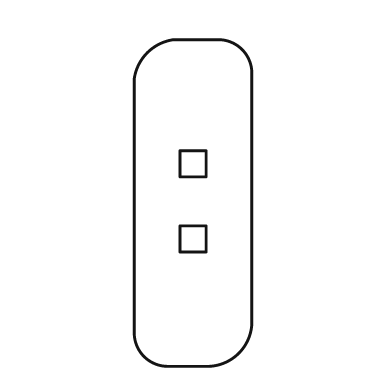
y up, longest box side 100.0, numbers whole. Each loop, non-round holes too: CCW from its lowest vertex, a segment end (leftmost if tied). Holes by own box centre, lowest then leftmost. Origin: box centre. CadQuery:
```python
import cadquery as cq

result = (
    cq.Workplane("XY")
    .moveTo(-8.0, -50.0)
    .lineTo(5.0, -50.0)
    .threePointArc((14.0, -46.0), (18.0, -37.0))
    .lineTo(18.0, 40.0)
    .threePointArc((15.0, 47.0), (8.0, 50.0))
    .lineTo(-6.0, 50.0)
    .threePointArc((-14.0, 46.0), (-18.0, 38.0))
    .lineTo(-18.0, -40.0)
    .threePointArc((-15.0, -47.0), (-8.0, -50.0))
    .close()
    .moveTo(-4.0, -15.0)
    .lineTo(4.0, -15.0)
    .lineTo(4.0, -7.0)
    .lineTo(-4.0, -7.0)
    .close()
    .moveTo(-4.0, 8.0)
    .lineTo(4.0, 8.0)
    .lineTo(4.0, 16.0)
    .lineTo(-4.0, 16.0)
    .close()
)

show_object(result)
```